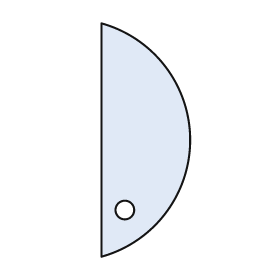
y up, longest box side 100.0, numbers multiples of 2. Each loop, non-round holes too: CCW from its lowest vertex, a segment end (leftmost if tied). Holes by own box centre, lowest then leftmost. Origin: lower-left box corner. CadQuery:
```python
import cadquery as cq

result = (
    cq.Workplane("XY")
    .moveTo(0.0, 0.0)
    .threePointArc((38.0, 50.0), (0.0, 100.0))
    .close()
    .moveTo(10.0, 20.0)
    .circle(4.0)
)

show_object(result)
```